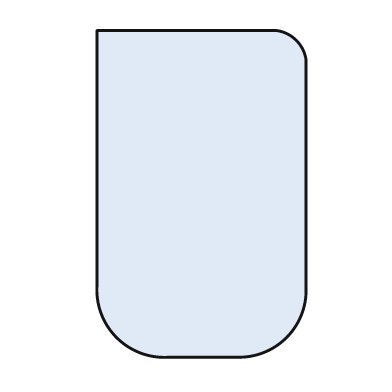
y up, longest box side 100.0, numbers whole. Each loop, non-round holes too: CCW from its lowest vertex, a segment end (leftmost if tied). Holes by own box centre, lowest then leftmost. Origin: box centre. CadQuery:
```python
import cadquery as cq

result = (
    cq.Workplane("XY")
    .moveTo(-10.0, -50.0)
    .lineTo(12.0, -50.0)
    .threePointArc((26.0, -44.0), (32.0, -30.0))
    .lineTo(32.0, 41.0)
    .threePointArc((29.0, 47.0), (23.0, 50.0))
    .lineTo(-32.0, 50.0)
    .lineTo(-32.0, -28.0)
    .threePointArc((-26.0, -44.0), (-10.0, -50.0))
    .close()
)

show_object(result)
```